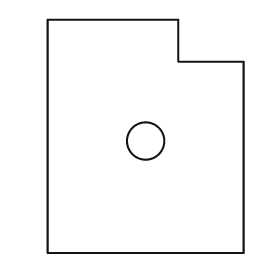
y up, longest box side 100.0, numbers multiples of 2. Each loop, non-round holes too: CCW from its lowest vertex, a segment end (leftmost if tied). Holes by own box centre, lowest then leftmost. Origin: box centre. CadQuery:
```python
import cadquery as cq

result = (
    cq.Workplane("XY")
    .moveTo(-42.0, -50.0)
    .lineTo(42.0, -50.0)
    .lineTo(42.0, 32.0)
    .lineTo(14.0, 32.0)
    .lineTo(14.0, 50.0)
    .lineTo(-42.0, 50.0)
    .close()
    .moveTo(0.0, -2.0)
    .circle(8.0)
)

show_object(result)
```